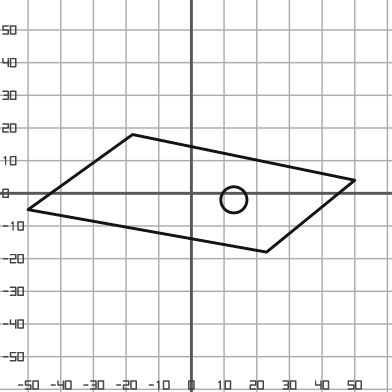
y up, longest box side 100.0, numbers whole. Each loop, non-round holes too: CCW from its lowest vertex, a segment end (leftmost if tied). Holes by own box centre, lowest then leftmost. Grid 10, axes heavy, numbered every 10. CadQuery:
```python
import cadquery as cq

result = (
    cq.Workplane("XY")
    .moveTo(23.0, -18.0)
    .lineTo(50.0, 4.0)
    .lineTo(-18.0, 18.0)
    .lineTo(-50.0, -5.0)
    .close()
    .moveTo(13.0, -2.0)
    .circle(4.0)
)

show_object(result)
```